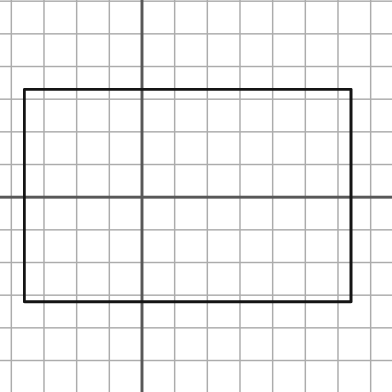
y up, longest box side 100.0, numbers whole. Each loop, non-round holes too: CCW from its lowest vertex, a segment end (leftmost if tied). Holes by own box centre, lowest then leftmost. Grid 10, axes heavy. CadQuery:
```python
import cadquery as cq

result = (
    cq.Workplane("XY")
    .moveTo(-36.0, -32.0)
    .lineTo(64.0, -32.0)
    .lineTo(64.0, 33.0)
    .lineTo(-36.0, 33.0)
    .close()
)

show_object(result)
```